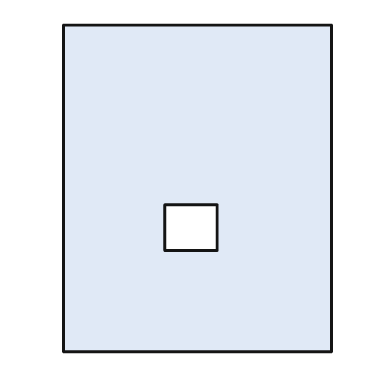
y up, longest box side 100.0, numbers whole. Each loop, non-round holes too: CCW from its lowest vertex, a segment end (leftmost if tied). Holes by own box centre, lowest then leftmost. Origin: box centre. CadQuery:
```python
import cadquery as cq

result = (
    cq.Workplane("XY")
    .moveTo(-41.0, -50.0)
    .lineTo(41.0, -50.0)
    .lineTo(41.0, 50.0)
    .lineTo(-41.0, 50.0)
    .close()
    .moveTo(-10.0, -19.0)
    .lineTo(6.0, -19.0)
    .lineTo(6.0, -5.0)
    .lineTo(-10.0, -5.0)
    .close()
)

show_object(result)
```